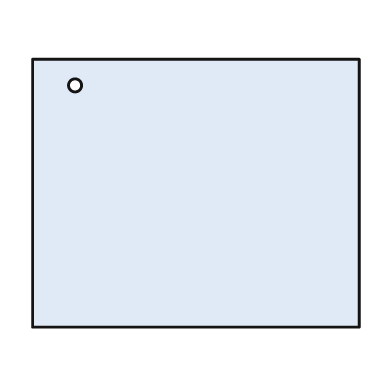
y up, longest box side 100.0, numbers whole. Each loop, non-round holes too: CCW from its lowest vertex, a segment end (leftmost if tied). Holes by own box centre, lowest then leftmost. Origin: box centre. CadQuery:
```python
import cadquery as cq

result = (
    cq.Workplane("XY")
    .moveTo(-50.0, -41.0)
    .lineTo(50.0, -41.0)
    .lineTo(50.0, 41.0)
    .lineTo(-50.0, 41.0)
    .close()
    .moveTo(-37.0, 33.0)
    .circle(2.0)
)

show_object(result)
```